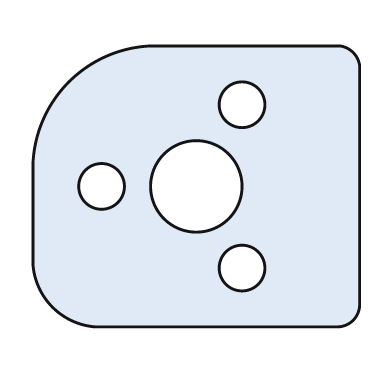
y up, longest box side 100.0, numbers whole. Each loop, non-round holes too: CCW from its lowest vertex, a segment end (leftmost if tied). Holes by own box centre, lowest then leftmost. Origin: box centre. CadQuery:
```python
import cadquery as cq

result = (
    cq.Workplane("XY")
    .moveTo(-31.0, -43.0)
    .lineTo(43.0, -43.0)
    .threePointArc((48.0, -41.0), (50.0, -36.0))
    .lineTo(50.0, 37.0)
    .threePointArc((48.0, 41.0), (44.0, 43.0))
    .lineTo(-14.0, 43.0)
    .threePointArc((-39.0, 32.0), (-50.0, 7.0))
    .lineTo(-50.0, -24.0)
    .threePointArc((-44.0, -37.0), (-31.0, -43.0))
    .close()
    .moveTo(14.0, -25.0)
    .circle(7.0)
    .moveTo(-29.0, 0.0)
    .circle(7.0)
    .moveTo(0.0, 0.0)
    .circle(14.0)
    .moveTo(14.0, 25.0)
    .circle(7.0)
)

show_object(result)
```